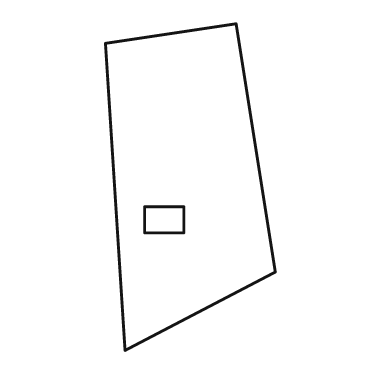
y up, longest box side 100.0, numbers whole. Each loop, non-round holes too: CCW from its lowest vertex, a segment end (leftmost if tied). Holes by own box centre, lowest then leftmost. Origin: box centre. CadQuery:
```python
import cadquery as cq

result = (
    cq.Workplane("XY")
    .moveTo(-20.0, -50.0)
    .lineTo(26.0, -26.0)
    .lineTo(14.0, 50.0)
    .lineTo(-26.0, 44.0)
    .close()
    .moveTo(-14.0, -14.0)
    .lineTo(-2.0, -14.0)
    .lineTo(-2.0, -6.0)
    .lineTo(-14.0, -6.0)
    .close()
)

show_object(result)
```